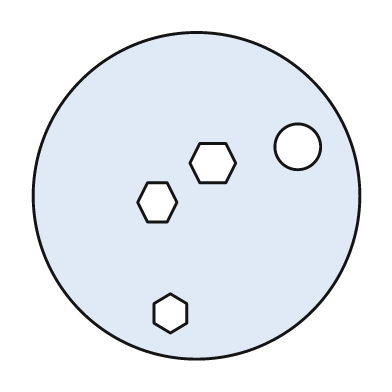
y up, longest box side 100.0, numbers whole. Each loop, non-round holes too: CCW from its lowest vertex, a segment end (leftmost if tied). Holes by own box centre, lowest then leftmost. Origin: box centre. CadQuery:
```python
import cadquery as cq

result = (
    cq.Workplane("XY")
    .moveTo(0.0, 0.0)
    .circle(50.0)
    .moveTo(-8.0, -42.0)
    .lineTo(-3.0, -39.0)
    .lineTo(-3.0, -33.0)
    .lineTo(-8.0, -30.0)
    .lineTo(-13.0, -33.0)
    .lineTo(-13.0, -39.0)
    .close()
    .moveTo(-15.0, -8.0)
    .lineTo(-9.0, -8.0)
    .lineTo(-6.0, -2.0)
    .lineTo(-9.0, 4.0)
    .lineTo(-15.0, 4.0)
    .lineTo(-18.0, -2.0)
    .close()
    .moveTo(1.0, 4.0)
    .lineTo(9.0, 4.0)
    .lineTo(12.0, 10.0)
    .lineTo(9.0, 16.0)
    .lineTo(1.0, 16.0)
    .lineTo(-2.0, 10.0)
    .close()
    .moveTo(31.0, 15.0)
    .circle(7.0)
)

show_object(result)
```